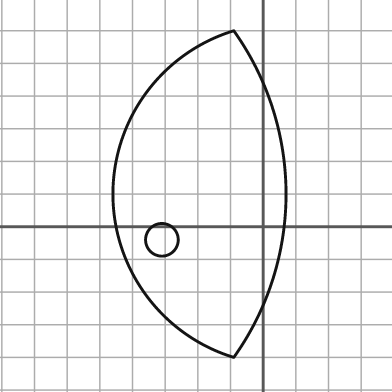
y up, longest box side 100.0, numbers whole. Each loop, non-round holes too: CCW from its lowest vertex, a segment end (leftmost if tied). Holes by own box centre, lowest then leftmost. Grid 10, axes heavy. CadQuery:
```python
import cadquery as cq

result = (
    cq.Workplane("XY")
    .moveTo(-9.0, -40.0)
    .threePointArc((7.0, 10.0), (-9.0, 60.0))
    .threePointArc((-46.0, 10.0), (-9.0, -40.0))
    .close()
    .moveTo(-31.0, -4.0)
    .circle(5.0)
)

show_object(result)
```